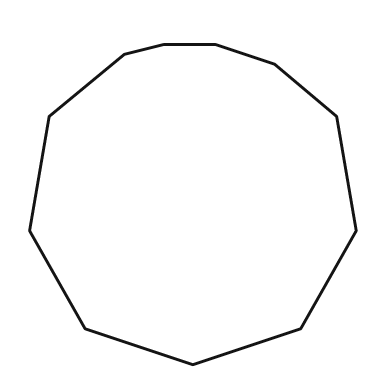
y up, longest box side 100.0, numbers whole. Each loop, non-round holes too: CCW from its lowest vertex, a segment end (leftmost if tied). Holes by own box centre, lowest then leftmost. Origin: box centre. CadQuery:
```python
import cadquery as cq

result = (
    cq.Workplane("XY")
    .moveTo(0.0, -49.0)
    .lineTo(33.0, -38.0)
    .lineTo(50.0, -8.0)
    .lineTo(44.0, 27.0)
    .lineTo(25.0, 43.0)
    .lineTo(7.0, 49.0)
    .lineTo(-9.0, 49.0)
    .lineTo(-21.0, 46.0)
    .lineTo(-44.0, 27.0)
    .lineTo(-50.0, -8.0)
    .lineTo(-33.0, -38.0)
    .close()
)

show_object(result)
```